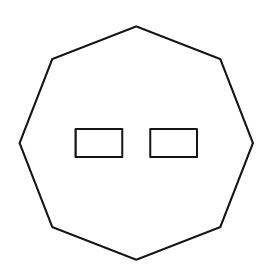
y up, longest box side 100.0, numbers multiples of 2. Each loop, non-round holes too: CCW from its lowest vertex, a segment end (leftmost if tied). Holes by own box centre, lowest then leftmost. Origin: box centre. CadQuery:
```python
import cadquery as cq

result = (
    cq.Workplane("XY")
    .moveTo(0.0, -50.0)
    .lineTo(36.0, -36.0)
    .lineTo(50.0, 0.0)
    .lineTo(36.0, 36.0)
    .lineTo(0.0, 50.0)
    .lineTo(-36.0, 36.0)
    .lineTo(-50.0, 0.0)
    .lineTo(-36.0, -36.0)
    .close()
    .moveTo(-26.0, -6.0)
    .lineTo(-6.0, -6.0)
    .lineTo(-6.0, 6.0)
    .lineTo(-26.0, 6.0)
    .close()
    .moveTo(6.0, -6.0)
    .lineTo(26.0, -6.0)
    .lineTo(26.0, 6.0)
    .lineTo(6.0, 6.0)
    .close()
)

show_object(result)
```